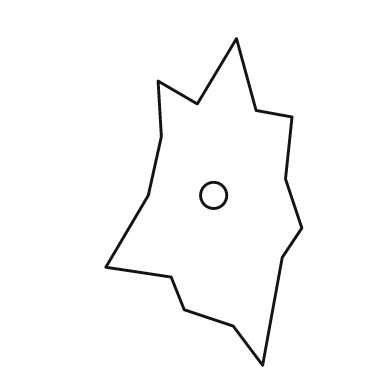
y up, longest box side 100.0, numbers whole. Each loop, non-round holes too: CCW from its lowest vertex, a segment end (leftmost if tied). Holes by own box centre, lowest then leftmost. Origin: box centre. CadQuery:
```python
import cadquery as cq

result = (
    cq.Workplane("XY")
    .moveTo(18.0, -50.0)
    .lineTo(24.0, -17.0)
    .lineTo(30.0, -8.0)
    .lineTo(25.0, 7.0)
    .lineTo(27.0, 26.0)
    .lineTo(16.0, 28.0)
    .lineTo(10.0, 50.0)
    .lineTo(-2.0, 30.0)
    .lineTo(-14.0, 37.0)
    .lineTo(-13.0, 20.0)
    .lineTo(-17.0, 2.0)
    .lineTo(-30.0, -20.0)
    .lineTo(-10.0, -23.0)
    .lineTo(-6.0, -33.0)
    .lineTo(9.0, -38.0)
    .close()
    .moveTo(3.0, 2.0)
    .circle(4.0)
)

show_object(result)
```